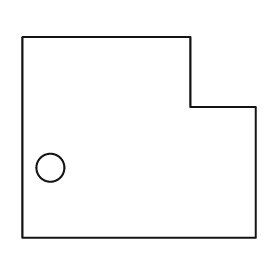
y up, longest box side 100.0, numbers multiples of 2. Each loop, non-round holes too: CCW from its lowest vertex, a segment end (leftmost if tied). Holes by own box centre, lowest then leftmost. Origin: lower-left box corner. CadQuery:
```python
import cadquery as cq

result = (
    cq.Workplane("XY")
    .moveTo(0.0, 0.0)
    .lineTo(100.0, 0.0)
    .lineTo(100.0, 56.0)
    .lineTo(72.0, 56.0)
    .lineTo(72.0, 86.0)
    .lineTo(0.0, 86.0)
    .close()
    .moveTo(12.0, 30.0)
    .circle(6.0)
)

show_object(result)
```